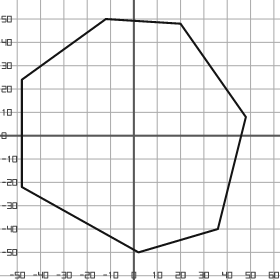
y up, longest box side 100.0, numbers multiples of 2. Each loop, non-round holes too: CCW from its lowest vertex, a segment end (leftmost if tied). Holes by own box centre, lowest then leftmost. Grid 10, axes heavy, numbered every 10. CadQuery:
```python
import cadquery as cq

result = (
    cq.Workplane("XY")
    .moveTo(2.0, -50.0)
    .lineTo(36.0, -40.0)
    .lineTo(48.0, 8.0)
    .lineTo(20.0, 48.0)
    .lineTo(-12.0, 50.0)
    .lineTo(-48.0, 24.0)
    .lineTo(-48.0, -22.0)
    .close()
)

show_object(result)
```